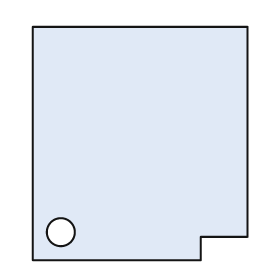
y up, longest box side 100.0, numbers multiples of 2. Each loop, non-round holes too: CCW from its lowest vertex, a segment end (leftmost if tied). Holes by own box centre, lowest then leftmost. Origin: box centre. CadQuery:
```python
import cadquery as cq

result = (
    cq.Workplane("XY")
    .moveTo(-46.0, -50.0)
    .lineTo(26.0, -50.0)
    .lineTo(26.0, -40.0)
    .lineTo(46.0, -40.0)
    .lineTo(46.0, 50.0)
    .lineTo(-46.0, 50.0)
    .close()
    .moveTo(-34.0, -38.0)
    .circle(6.0)
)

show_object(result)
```